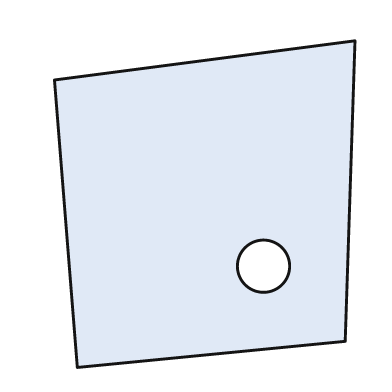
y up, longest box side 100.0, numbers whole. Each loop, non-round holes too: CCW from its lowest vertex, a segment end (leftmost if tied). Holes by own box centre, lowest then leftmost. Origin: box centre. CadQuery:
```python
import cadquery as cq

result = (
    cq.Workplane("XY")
    .moveTo(-39.0, -50.0)
    .lineTo(43.0, -42.0)
    .lineTo(46.0, 50.0)
    .lineTo(-46.0, 38.0)
    .close()
    .moveTo(18.0, -19.0)
    .circle(8.0)
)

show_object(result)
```